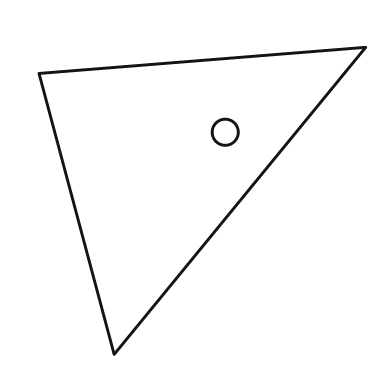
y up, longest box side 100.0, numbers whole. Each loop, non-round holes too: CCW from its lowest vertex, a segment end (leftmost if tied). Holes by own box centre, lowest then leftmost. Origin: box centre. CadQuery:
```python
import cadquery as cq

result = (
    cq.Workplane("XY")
    .moveTo(-27.0, -47.0)
    .lineTo(50.0, 47.0)
    .lineTo(-50.0, 39.0)
    .close()
    .moveTo(7.0, 21.0)
    .circle(4.0)
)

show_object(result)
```